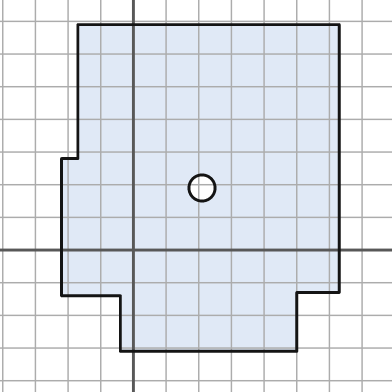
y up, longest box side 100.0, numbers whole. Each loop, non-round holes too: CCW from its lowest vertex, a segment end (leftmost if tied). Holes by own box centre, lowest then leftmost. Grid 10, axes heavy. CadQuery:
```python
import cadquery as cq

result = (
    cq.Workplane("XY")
    .moveTo(-4.0, -31.0)
    .lineTo(50.0, -31.0)
    .lineTo(50.0, -13.0)
    .lineTo(63.0, -13.0)
    .lineTo(63.0, 69.0)
    .lineTo(-17.0, 69.0)
    .lineTo(-17.0, 28.0)
    .lineTo(-22.0, 28.0)
    .lineTo(-22.0, -14.0)
    .lineTo(-4.0, -14.0)
    .close()
    .moveTo(21.0, 19.0)
    .circle(4.0)
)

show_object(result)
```